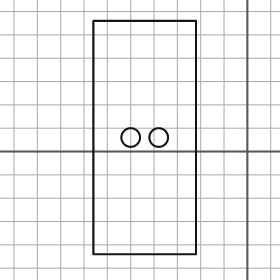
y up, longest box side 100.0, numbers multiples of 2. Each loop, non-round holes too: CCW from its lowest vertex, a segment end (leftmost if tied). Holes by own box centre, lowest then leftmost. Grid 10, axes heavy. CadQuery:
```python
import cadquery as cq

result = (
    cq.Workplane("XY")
    .moveTo(-66.0, -44.0)
    .lineTo(-22.0, -44.0)
    .lineTo(-22.0, 56.0)
    .lineTo(-66.0, 56.0)
    .close()
    .moveTo(-50.0, 6.0)
    .circle(4.0)
    .moveTo(-38.0, 6.0)
    .circle(4.0)
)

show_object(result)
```